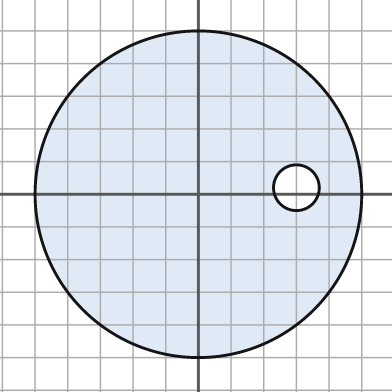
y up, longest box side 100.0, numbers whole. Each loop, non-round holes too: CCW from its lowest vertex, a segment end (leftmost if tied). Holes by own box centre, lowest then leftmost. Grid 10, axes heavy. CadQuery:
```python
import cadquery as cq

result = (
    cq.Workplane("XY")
    .moveTo(0.0, 0.0)
    .circle(50.0)
    .moveTo(30.0, 2.0)
    .circle(7.0)
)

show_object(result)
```